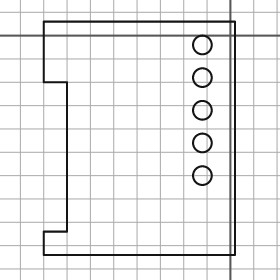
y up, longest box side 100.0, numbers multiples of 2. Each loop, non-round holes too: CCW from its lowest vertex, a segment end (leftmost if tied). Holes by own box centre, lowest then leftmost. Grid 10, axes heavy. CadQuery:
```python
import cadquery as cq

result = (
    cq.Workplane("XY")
    .moveTo(-80.0, -94.0)
    .lineTo(2.0, -94.0)
    .lineTo(2.0, 6.0)
    .lineTo(-80.0, 6.0)
    .lineTo(-80.0, -20.0)
    .lineTo(-70.0, -20.0)
    .lineTo(-70.0, -84.0)
    .lineTo(-80.0, -84.0)
    .close()
    .moveTo(-12.0, -60.0)
    .circle(4.0)
    .moveTo(-12.0, -46.0)
    .circle(4.0)
    .moveTo(-12.0, -32.0)
    .circle(4.0)
    .moveTo(-12.0, -18.0)
    .circle(4.0)
    .moveTo(-12.0, -4.0)
    .circle(4.0)
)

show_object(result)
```